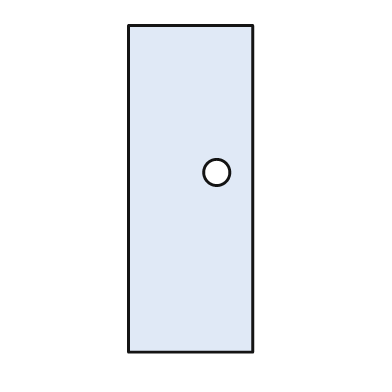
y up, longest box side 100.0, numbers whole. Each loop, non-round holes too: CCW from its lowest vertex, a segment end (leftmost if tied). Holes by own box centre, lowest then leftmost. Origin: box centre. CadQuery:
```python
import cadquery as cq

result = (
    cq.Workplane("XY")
    .moveTo(-19.0, -50.0)
    .lineTo(19.0, -50.0)
    .lineTo(19.0, 50.0)
    .lineTo(-19.0, 50.0)
    .close()
    .moveTo(8.0, 5.0)
    .circle(4.0)
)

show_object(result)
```